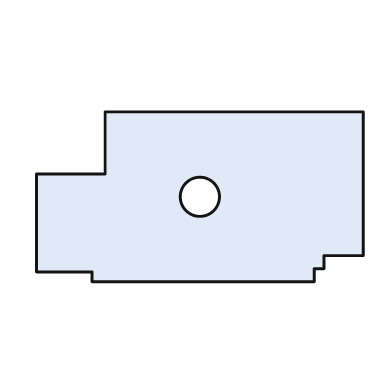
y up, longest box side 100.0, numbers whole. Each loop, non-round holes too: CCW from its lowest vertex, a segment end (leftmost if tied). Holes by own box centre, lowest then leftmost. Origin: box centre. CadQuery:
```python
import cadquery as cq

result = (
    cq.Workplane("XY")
    .moveTo(-33.0, -26.0)
    .lineTo(35.0, -26.0)
    .lineTo(35.0, -22.0)
    .lineTo(38.0, -22.0)
    .lineTo(38.0, -18.0)
    .lineTo(50.0, -18.0)
    .lineTo(50.0, 26.0)
    .lineTo(-29.0, 26.0)
    .lineTo(-29.0, 7.0)
    .lineTo(-50.0, 7.0)
    .lineTo(-50.0, -23.0)
    .lineTo(-33.0, -23.0)
    .close()
    .moveTo(0.0, 0.0)
    .circle(6.0)
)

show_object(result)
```